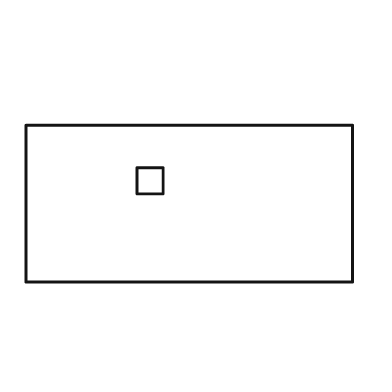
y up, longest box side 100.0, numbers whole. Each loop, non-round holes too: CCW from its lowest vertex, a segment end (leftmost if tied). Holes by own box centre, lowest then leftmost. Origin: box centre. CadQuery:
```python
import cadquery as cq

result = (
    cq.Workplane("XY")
    .moveTo(-50.0, -24.0)
    .lineTo(50.0, -24.0)
    .lineTo(50.0, 24.0)
    .lineTo(-50.0, 24.0)
    .close()
    .moveTo(-16.0, 3.0)
    .lineTo(-8.0, 3.0)
    .lineTo(-8.0, 11.0)
    .lineTo(-16.0, 11.0)
    .close()
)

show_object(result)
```